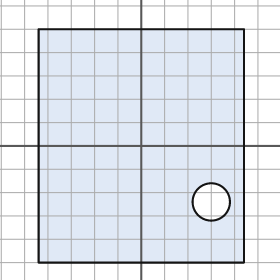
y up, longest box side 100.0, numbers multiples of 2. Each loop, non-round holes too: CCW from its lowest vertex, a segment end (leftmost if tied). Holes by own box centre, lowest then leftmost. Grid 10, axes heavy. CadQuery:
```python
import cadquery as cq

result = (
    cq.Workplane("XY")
    .moveTo(-44.0, -50.0)
    .lineTo(44.0, -50.0)
    .lineTo(44.0, 50.0)
    .lineTo(-44.0, 50.0)
    .close()
    .moveTo(30.0, -24.0)
    .circle(8.0)
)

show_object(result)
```